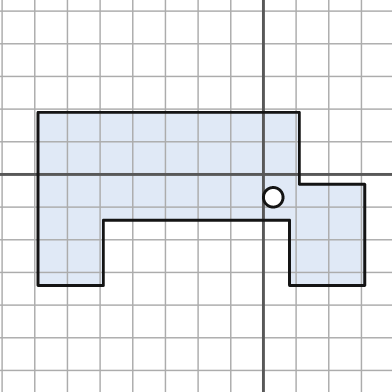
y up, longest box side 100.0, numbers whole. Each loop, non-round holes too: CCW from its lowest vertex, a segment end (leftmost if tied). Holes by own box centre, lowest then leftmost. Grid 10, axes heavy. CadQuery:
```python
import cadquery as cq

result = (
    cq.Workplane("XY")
    .moveTo(-69.0, -34.0)
    .lineTo(-49.0, -34.0)
    .lineTo(-49.0, -14.0)
    .lineTo(8.0, -14.0)
    .lineTo(8.0, -34.0)
    .lineTo(31.0, -34.0)
    .lineTo(31.0, -3.0)
    .lineTo(11.0, -3.0)
    .lineTo(11.0, 19.0)
    .lineTo(-69.0, 19.0)
    .close()
    .moveTo(3.0, -7.0)
    .circle(3.0)
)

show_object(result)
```